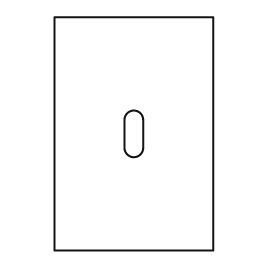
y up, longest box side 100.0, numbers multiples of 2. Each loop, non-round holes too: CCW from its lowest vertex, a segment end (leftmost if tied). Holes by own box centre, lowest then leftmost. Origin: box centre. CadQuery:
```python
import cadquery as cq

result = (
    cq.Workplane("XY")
    .moveTo(-34.0, -50.0)
    .lineTo(34.0, -50.0)
    .lineTo(34.0, 50.0)
    .lineTo(-34.0, 50.0)
    .close()
    .moveTo(-4.0, -6.0)
    .threePointArc((0.0, -10.0), (4.0, -6.0))
    .lineTo(4.0, 6.0)
    .threePointArc((0.0, 10.0), (-4.0, 6.0))
    .close()
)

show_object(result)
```